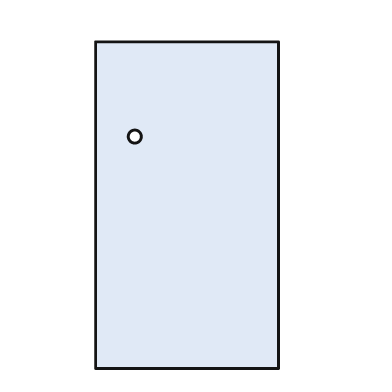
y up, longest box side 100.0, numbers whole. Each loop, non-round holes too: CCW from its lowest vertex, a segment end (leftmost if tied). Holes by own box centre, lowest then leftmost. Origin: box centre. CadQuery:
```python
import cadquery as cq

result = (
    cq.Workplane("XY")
    .moveTo(-28.0, -50.0)
    .lineTo(28.0, -50.0)
    .lineTo(28.0, 50.0)
    .lineTo(-28.0, 50.0)
    .close()
    .moveTo(-16.0, 21.0)
    .circle(2.0)
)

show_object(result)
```